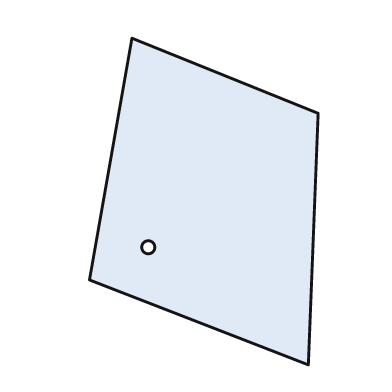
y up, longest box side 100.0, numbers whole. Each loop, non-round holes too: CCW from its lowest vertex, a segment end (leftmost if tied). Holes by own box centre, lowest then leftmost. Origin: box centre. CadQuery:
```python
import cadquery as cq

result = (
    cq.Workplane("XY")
    .moveTo(32.0, -50.0)
    .lineTo(35.0, 27.0)
    .lineTo(-22.0, 50.0)
    .lineTo(-35.0, -24.0)
    .close()
    .moveTo(-17.0, -14.0)
    .circle(2.0)
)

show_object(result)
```